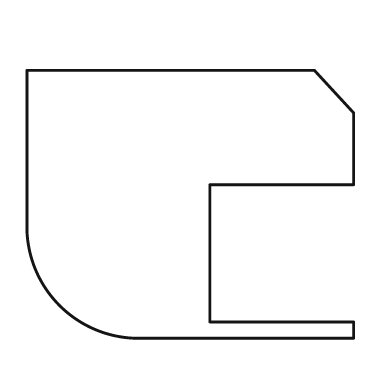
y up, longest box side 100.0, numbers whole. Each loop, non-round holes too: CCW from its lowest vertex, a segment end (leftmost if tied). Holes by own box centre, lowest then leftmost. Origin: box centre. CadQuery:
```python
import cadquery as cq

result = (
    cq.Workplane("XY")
    .moveTo(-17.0, -41.0)
    .lineTo(50.0, -41.0)
    .lineTo(50.0, -36.0)
    .lineTo(6.0, -36.0)
    .lineTo(6.0, 6.0)
    .lineTo(50.0, 6.0)
    .lineTo(50.0, 28.0)
    .lineTo(38.0, 41.0)
    .lineTo(-50.0, 41.0)
    .lineTo(-50.0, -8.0)
    .threePointArc((-40.0, -31.0), (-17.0, -41.0))
    .close()
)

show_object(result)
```